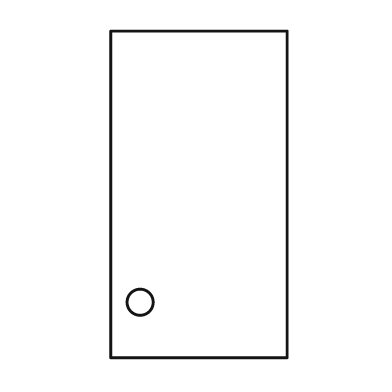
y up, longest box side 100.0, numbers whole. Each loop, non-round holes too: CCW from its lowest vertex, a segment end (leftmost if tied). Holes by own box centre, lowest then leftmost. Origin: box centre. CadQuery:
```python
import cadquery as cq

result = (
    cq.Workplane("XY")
    .moveTo(-27.0, -50.0)
    .lineTo(27.0, -50.0)
    .lineTo(27.0, 50.0)
    .lineTo(-27.0, 50.0)
    .close()
    .moveTo(-18.0, -33.0)
    .circle(4.0)
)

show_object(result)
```